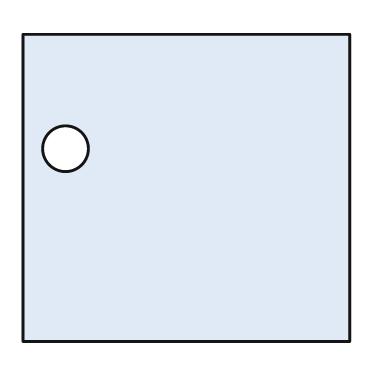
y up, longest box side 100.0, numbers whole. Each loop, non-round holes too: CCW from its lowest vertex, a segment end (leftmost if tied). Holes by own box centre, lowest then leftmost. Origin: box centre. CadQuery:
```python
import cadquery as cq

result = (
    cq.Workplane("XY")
    .moveTo(-50.0, -47.0)
    .lineTo(50.0, -47.0)
    .lineTo(50.0, 47.0)
    .lineTo(-50.0, 47.0)
    .close()
    .moveTo(-37.0, 12.0)
    .circle(7.0)
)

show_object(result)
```